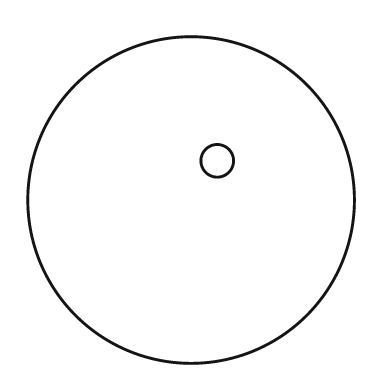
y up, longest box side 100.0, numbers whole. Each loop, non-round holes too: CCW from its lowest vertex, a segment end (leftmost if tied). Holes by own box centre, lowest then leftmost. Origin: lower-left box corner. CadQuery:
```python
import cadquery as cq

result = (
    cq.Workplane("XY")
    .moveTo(50.0, 50.0)
    .circle(50.0)
    .moveTo(58.0, 62.0)
    .circle(5.0)
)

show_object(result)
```